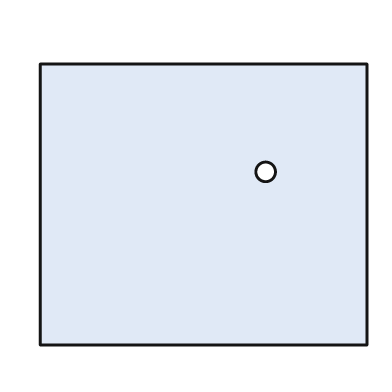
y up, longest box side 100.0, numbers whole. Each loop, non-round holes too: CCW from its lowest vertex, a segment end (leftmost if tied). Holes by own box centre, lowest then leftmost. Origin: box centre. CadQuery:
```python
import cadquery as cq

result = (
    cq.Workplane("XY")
    .moveTo(-50.0, -43.0)
    .lineTo(50.0, -43.0)
    .lineTo(50.0, 43.0)
    .lineTo(-50.0, 43.0)
    .close()
    .moveTo(19.0, 10.0)
    .circle(3.0)
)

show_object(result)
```